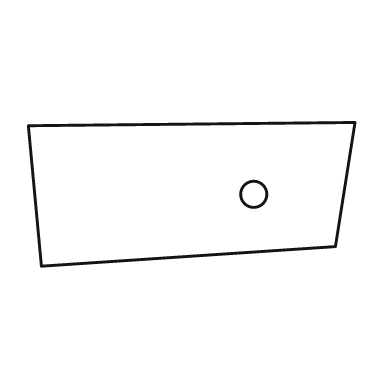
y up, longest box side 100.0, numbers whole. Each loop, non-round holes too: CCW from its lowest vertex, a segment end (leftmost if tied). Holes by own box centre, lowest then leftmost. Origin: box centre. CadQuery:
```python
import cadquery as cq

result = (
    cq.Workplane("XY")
    .moveTo(-46.0, -22.0)
    .lineTo(44.0, -16.0)
    .lineTo(50.0, 22.0)
    .lineTo(-50.0, 21.0)
    .close()
    .moveTo(19.0, 0.0)
    .circle(4.0)
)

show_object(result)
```